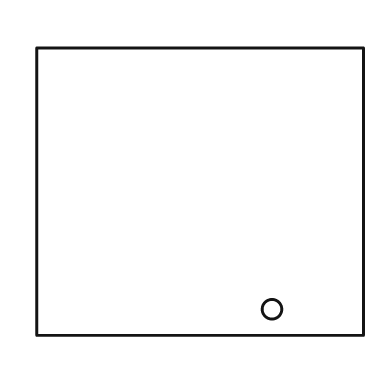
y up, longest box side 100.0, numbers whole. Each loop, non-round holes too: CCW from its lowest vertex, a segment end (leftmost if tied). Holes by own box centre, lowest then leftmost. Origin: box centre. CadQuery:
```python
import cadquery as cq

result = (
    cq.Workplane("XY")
    .moveTo(-50.0, -44.0)
    .lineTo(50.0, -44.0)
    .lineTo(50.0, 44.0)
    .lineTo(-50.0, 44.0)
    .close()
    .moveTo(22.0, -36.0)
    .circle(3.0)
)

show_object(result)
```